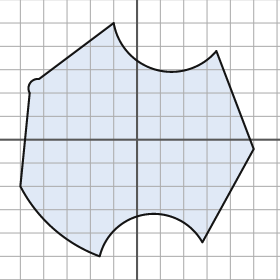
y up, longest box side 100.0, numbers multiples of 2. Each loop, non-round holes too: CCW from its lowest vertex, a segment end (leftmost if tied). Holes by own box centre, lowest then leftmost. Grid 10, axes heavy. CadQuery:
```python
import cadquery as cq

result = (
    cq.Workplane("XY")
    .moveTo(-16.0, -50.0)
    .threePointArc((4.0, -32.0), (28.0, -44.0))
    .lineTo(50.0, -4.0)
    .lineTo(34.0, 38.0)
    .threePointArc((8.0, 30.0), (-10.0, 50.0))
    .lineTo(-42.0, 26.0)
    .threePointArc((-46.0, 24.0), (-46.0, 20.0))
    .lineTo(-50.0, -20.0)
    .threePointArc((-36.0, -38.0), (-16.0, -50.0))
    .close()
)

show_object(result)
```